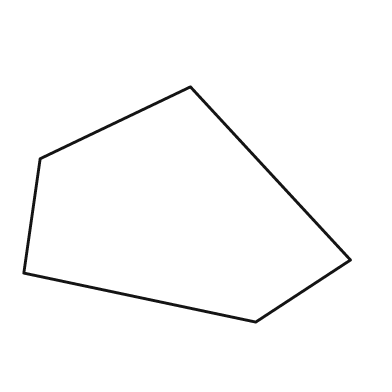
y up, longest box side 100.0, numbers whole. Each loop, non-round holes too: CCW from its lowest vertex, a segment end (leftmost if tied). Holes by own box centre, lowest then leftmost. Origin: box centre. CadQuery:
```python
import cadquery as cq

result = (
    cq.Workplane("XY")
    .moveTo(21.0, -36.0)
    .lineTo(50.0, -17.0)
    .lineTo(1.0, 36.0)
    .lineTo(-45.0, 14.0)
    .lineTo(-50.0, -21.0)
    .close()
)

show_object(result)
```